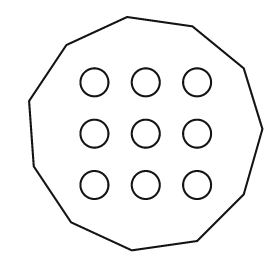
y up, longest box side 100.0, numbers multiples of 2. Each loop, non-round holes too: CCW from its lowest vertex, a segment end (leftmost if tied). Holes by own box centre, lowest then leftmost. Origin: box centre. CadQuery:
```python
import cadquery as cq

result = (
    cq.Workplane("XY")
    .moveTo(-6.0, -50.0)
    .lineTo(22.0, -46.0)
    .lineTo(42.0, -26.0)
    .lineTo(50.0, 2.0)
    .lineTo(42.0, 28.0)
    .lineTo(20.0, 46.0)
    .lineTo(-8.0, 50.0)
    .lineTo(-34.0, 38.0)
    .lineTo(-50.0, 14.0)
    .lineTo(-48.0, -14.0)
    .lineTo(-32.0, -38.0)
    .close()
    .moveTo(-22.0, -22.0)
    .circle(6.0)
    .moveTo(0.0, -22.0)
    .circle(6.0)
    .moveTo(22.0, -22.0)
    .circle(6.0)
    .moveTo(-22.0, 0.0)
    .circle(6.0)
    .moveTo(0.0, 0.0)
    .circle(6.0)
    .moveTo(22.0, 0.0)
    .circle(6.0)
    .moveTo(-22.0, 22.0)
    .circle(6.0)
    .moveTo(0.0, 22.0)
    .circle(6.0)
    .moveTo(22.0, 22.0)
    .circle(6.0)
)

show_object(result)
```